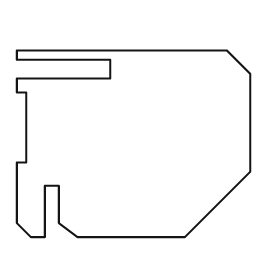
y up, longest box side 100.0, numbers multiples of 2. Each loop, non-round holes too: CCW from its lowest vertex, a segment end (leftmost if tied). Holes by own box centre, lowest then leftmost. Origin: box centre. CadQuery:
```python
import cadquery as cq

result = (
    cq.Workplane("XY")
    .moveTo(-44.0, -40.0)
    .lineTo(-38.0, -40.0)
    .lineTo(-38.0, -18.0)
    .lineTo(-32.0, -18.0)
    .lineTo(-32.0, -34.0)
    .lineTo(-24.0, -40.0)
    .lineTo(22.0, -40.0)
    .lineTo(50.0, -12.0)
    .lineTo(50.0, 30.0)
    .lineTo(40.0, 40.0)
    .lineTo(-50.0, 40.0)
    .lineTo(-50.0, 36.0)
    .lineTo(-10.0, 36.0)
    .lineTo(-10.0, 28.0)
    .lineTo(-50.0, 28.0)
    .lineTo(-50.0, 22.0)
    .lineTo(-46.0, 22.0)
    .lineTo(-46.0, -8.0)
    .lineTo(-50.0, -8.0)
    .lineTo(-50.0, -34.0)
    .close()
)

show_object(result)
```